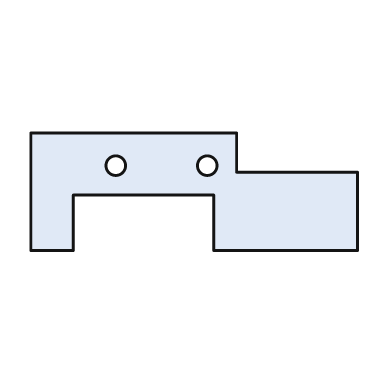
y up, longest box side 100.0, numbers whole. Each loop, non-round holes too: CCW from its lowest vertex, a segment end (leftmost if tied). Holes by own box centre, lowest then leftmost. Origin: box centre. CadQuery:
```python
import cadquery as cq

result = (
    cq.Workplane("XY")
    .moveTo(-50.0, -18.0)
    .lineTo(-37.0, -18.0)
    .lineTo(-37.0, -1.0)
    .lineTo(6.0, -1.0)
    .lineTo(6.0, -18.0)
    .lineTo(50.0, -18.0)
    .lineTo(50.0, 6.0)
    .lineTo(13.0, 6.0)
    .lineTo(13.0, 18.0)
    .lineTo(-50.0, 18.0)
    .close()
    .moveTo(-24.0, 8.0)
    .circle(3.0)
    .moveTo(4.0, 8.0)
    .circle(3.0)
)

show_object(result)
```